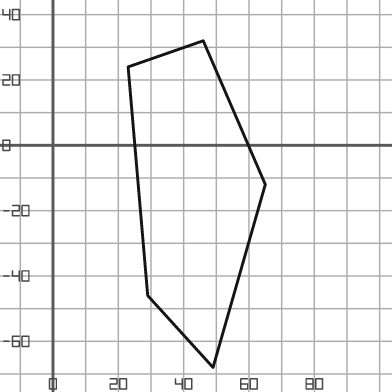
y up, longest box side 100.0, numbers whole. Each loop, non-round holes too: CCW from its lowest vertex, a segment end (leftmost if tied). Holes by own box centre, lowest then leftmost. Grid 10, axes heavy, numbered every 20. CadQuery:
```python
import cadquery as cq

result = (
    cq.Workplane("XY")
    .moveTo(49.0, -68.0)
    .lineTo(65.0, -12.0)
    .lineTo(46.0, 32.0)
    .lineTo(23.0, 24.0)
    .lineTo(29.0, -46.0)
    .close()
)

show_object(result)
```